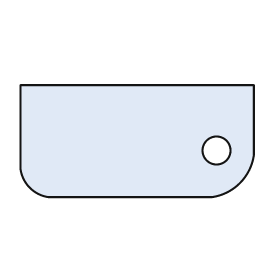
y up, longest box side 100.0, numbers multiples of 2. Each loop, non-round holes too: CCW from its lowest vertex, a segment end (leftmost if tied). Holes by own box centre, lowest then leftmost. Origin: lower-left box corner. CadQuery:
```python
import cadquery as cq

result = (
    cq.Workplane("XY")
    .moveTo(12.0, 0.0)
    .lineTo(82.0, 0.0)
    .threePointArc((94.0, 6.0), (100.0, 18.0))
    .lineTo(100.0, 48.0)
    .lineTo(0.0, 48.0)
    .lineTo(0.0, 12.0)
    .threePointArc((4.0, 4.0), (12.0, 0.0))
    .close()
    .moveTo(84.0, 20.0)
    .circle(6.0)
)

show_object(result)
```